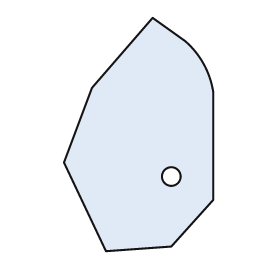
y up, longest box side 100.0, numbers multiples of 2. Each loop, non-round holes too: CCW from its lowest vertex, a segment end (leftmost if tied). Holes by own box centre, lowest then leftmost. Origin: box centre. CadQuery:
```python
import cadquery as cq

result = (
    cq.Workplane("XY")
    .moveTo(-14.0, -50.0)
    .lineTo(14.0, -48.0)
    .lineTo(32.0, -28.0)
    .lineTo(32.0, 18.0)
    .threePointArc((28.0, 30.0), (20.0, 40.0))
    .lineTo(6.0, 50.0)
    .lineTo(-20.0, 20.0)
    .lineTo(-32.0, -12.0)
    .close()
    .moveTo(14.0, -18.0)
    .circle(4.0)
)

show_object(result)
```